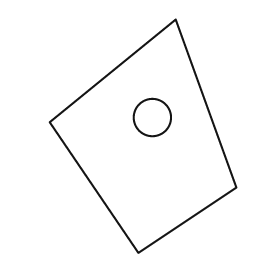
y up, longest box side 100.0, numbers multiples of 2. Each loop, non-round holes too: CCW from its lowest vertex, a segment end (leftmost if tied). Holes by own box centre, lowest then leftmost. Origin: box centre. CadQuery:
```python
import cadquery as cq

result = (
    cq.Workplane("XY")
    .moveTo(-2.0, -50.0)
    .lineTo(40.0, -22.0)
    .lineTo(14.0, 50.0)
    .lineTo(-40.0, 6.0)
    .close()
    .moveTo(4.0, 8.0)
    .circle(8.0)
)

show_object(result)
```